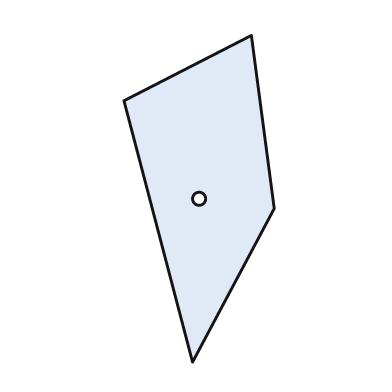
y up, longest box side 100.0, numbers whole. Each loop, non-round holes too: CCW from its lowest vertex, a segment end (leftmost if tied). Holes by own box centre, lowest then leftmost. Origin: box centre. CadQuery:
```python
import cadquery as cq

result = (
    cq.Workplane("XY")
    .moveTo(-2.0, -50.0)
    .lineTo(23.0, -3.0)
    .lineTo(16.0, 50.0)
    .lineTo(-23.0, 30.0)
    .close()
    .moveTo(0.0, 0.0)
    .circle(2.0)
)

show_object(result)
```